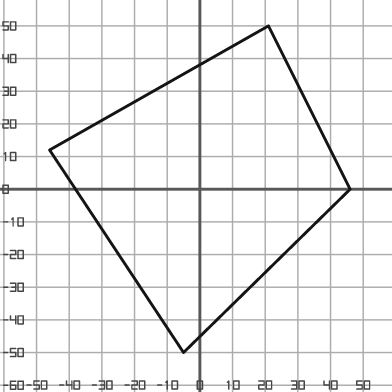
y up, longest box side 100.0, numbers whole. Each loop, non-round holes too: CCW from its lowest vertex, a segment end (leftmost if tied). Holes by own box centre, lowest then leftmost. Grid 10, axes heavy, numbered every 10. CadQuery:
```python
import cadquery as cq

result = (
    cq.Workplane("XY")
    .moveTo(-5.0, -50.0)
    .lineTo(46.0, 0.0)
    .lineTo(21.0, 50.0)
    .lineTo(-46.0, 12.0)
    .close()
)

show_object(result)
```